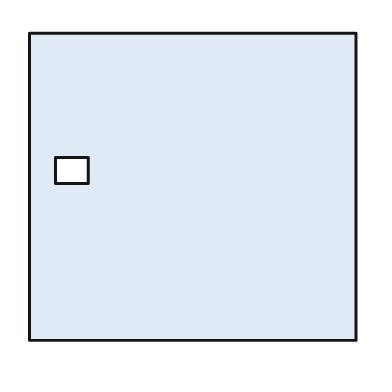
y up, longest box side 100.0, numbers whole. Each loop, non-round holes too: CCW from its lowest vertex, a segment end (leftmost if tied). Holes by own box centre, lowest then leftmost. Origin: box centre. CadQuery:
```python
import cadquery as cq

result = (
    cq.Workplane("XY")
    .moveTo(-50.0, -47.0)
    .lineTo(50.0, -47.0)
    .lineTo(50.0, 47.0)
    .lineTo(-50.0, 47.0)
    .close()
    .moveTo(-42.0, 1.0)
    .lineTo(-32.0, 1.0)
    .lineTo(-32.0, 9.0)
    .lineTo(-42.0, 9.0)
    .close()
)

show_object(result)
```